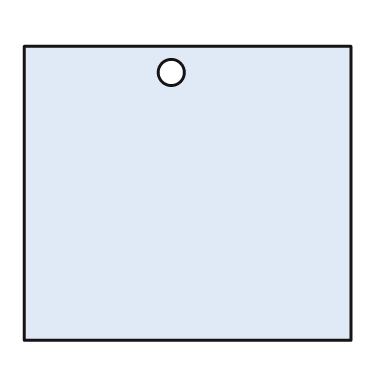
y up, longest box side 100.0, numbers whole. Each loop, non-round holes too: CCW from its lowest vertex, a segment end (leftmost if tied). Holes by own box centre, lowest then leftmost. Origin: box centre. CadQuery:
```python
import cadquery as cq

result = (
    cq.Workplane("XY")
    .moveTo(-50.0, -45.0)
    .lineTo(50.0, -45.0)
    .lineTo(50.0, 45.0)
    .lineTo(-50.0, 45.0)
    .close()
    .moveTo(-5.0, 37.0)
    .circle(4.0)
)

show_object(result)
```